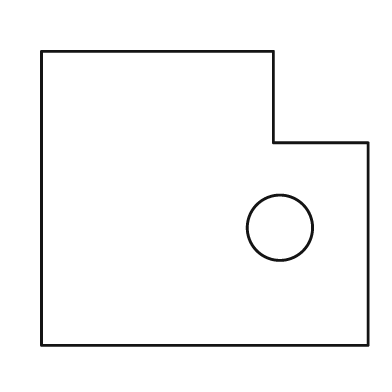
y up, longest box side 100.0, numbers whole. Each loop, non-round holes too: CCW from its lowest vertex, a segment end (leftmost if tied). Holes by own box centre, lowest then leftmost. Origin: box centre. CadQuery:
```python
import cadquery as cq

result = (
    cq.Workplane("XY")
    .moveTo(-50.0, -45.0)
    .lineTo(50.0, -45.0)
    .lineTo(50.0, 17.0)
    .lineTo(21.0, 17.0)
    .lineTo(21.0, 45.0)
    .lineTo(-50.0, 45.0)
    .close()
    .moveTo(23.0, -9.0)
    .circle(10.0)
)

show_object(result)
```